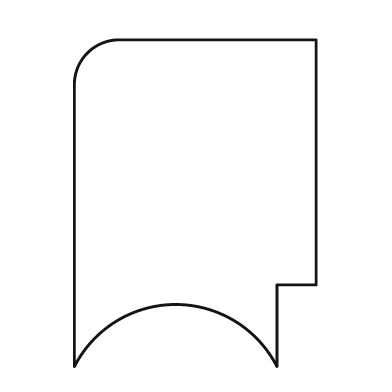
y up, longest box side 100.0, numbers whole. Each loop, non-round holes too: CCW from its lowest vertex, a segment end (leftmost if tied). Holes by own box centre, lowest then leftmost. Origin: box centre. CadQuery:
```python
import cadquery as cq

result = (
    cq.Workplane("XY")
    .moveTo(-37.0, -50.0)
    .threePointArc((-6.0, -31.0), (25.0, -50.0))
    .lineTo(25.0, -25.0)
    .lineTo(37.0, -25.0)
    .lineTo(37.0, 50.0)
    .lineTo(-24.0, 50.0)
    .threePointArc((-33.0, 46.0), (-37.0, 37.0))
    .close()
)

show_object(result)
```